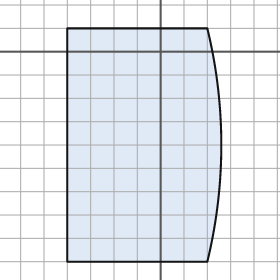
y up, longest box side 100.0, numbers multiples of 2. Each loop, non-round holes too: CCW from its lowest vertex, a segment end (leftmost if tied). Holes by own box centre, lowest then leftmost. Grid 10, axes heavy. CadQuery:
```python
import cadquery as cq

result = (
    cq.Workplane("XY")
    .moveTo(-40.0, -90.0)
    .lineTo(20.0, -90.0)
    .threePointArc((26.0, -40.0), (20.0, 10.0))
    .lineTo(-40.0, 10.0)
    .close()
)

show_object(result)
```